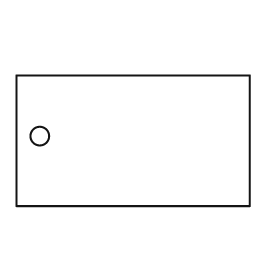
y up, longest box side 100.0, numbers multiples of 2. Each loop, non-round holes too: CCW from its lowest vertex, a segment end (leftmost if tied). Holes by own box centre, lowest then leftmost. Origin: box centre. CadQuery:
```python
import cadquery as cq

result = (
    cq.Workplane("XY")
    .moveTo(-50.0, -28.0)
    .lineTo(50.0, -28.0)
    .lineTo(50.0, 28.0)
    .lineTo(-50.0, 28.0)
    .close()
    .moveTo(-40.0, 2.0)
    .circle(4.0)
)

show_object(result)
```